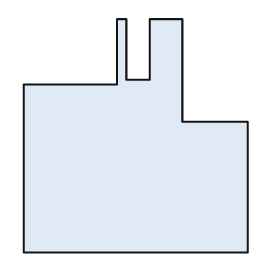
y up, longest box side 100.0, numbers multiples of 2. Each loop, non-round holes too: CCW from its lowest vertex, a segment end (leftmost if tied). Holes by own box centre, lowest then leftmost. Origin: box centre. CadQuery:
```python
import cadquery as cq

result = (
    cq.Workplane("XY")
    .moveTo(-48.0, -50.0)
    .lineTo(48.0, -50.0)
    .lineTo(48.0, 6.0)
    .lineTo(20.0, 6.0)
    .lineTo(20.0, 50.0)
    .lineTo(6.0, 50.0)
    .lineTo(6.0, 24.0)
    .lineTo(-4.0, 24.0)
    .lineTo(-4.0, 50.0)
    .lineTo(-8.0, 50.0)
    .lineTo(-8.0, 22.0)
    .lineTo(-48.0, 22.0)
    .close()
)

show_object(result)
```